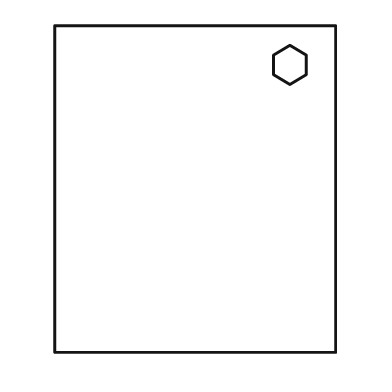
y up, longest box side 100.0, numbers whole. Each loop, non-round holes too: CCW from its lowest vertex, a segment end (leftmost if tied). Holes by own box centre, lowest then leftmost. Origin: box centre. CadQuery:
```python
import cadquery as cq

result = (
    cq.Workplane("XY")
    .moveTo(-43.0, -50.0)
    .lineTo(43.0, -50.0)
    .lineTo(43.0, 50.0)
    .lineTo(-43.0, 50.0)
    .close()
    .moveTo(29.0, 32.0)
    .lineTo(34.0, 35.0)
    .lineTo(34.0, 41.0)
    .lineTo(29.0, 44.0)
    .lineTo(24.0, 41.0)
    .lineTo(24.0, 35.0)
    .close()
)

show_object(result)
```